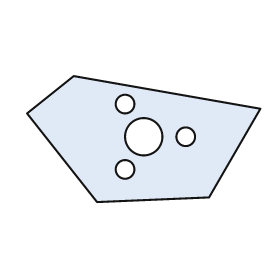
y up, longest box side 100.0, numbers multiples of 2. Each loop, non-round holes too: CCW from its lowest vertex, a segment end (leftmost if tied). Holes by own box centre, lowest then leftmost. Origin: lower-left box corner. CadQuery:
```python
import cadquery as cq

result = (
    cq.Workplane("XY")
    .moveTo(30.0, 0.0)
    .lineTo(78.0, 2.0)
    .lineTo(100.0, 40.0)
    .lineTo(20.0, 54.0)
    .lineTo(0.0, 38.0)
    .close()
    .moveTo(42.0, 14.0)
    .circle(4.0)
    .moveTo(50.0, 28.0)
    .circle(8.0)
    .moveTo(68.0, 28.0)
    .circle(4.0)
    .moveTo(42.0, 42.0)
    .circle(4.0)
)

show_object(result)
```